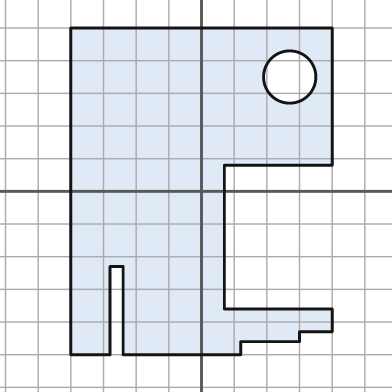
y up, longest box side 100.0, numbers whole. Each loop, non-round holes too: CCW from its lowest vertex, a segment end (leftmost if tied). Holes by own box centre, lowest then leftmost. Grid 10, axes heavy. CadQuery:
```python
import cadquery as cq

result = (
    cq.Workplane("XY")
    .moveTo(-40.0, -50.0)
    .lineTo(-28.0, -50.0)
    .lineTo(-28.0, -23.0)
    .lineTo(-24.0, -23.0)
    .lineTo(-24.0, -50.0)
    .lineTo(12.0, -50.0)
    .lineTo(12.0, -46.0)
    .lineTo(30.0, -46.0)
    .lineTo(30.0, -43.0)
    .lineTo(40.0, -43.0)
    .lineTo(40.0, -36.0)
    .lineTo(7.0, -36.0)
    .lineTo(7.0, 8.0)
    .lineTo(40.0, 8.0)
    .lineTo(40.0, 50.0)
    .lineTo(-40.0, 50.0)
    .close()
    .moveTo(27.0, 35.0)
    .circle(8.0)
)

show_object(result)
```